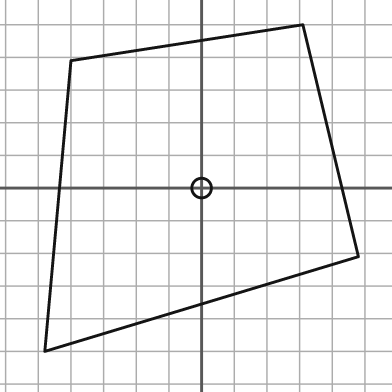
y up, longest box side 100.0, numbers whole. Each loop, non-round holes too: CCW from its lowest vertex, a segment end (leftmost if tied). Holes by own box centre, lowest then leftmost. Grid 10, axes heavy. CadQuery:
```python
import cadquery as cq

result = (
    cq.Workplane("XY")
    .moveTo(-48.0, -50.0)
    .lineTo(48.0, -21.0)
    .lineTo(31.0, 50.0)
    .lineTo(-40.0, 39.0)
    .close()
    .moveTo(0.0, 0.0)
    .circle(3.0)
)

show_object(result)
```